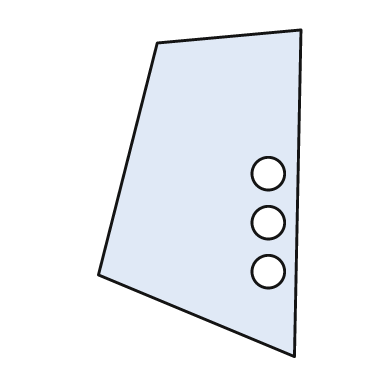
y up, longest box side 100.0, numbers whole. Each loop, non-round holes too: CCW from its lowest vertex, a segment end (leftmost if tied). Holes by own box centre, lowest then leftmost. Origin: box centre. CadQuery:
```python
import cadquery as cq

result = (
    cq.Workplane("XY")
    .moveTo(29.0, -50.0)
    .lineTo(31.0, 50.0)
    .lineTo(-13.0, 46.0)
    .lineTo(-31.0, -25.0)
    .close()
    .moveTo(21.0, -24.0)
    .circle(5.0)
    .moveTo(21.0, -9.0)
    .circle(5.0)
    .moveTo(21.0, 6.0)
    .circle(5.0)
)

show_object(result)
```